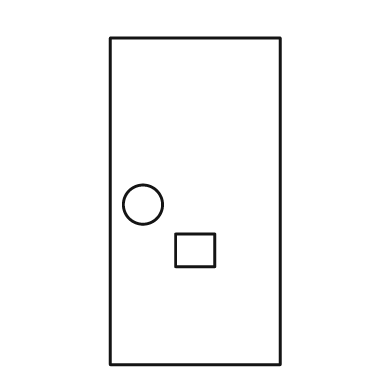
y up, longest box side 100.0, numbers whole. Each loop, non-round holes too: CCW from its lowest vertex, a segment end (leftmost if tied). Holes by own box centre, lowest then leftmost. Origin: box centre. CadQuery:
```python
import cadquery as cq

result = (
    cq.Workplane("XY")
    .moveTo(-26.0, -50.0)
    .lineTo(26.0, -50.0)
    .lineTo(26.0, 50.0)
    .lineTo(-26.0, 50.0)
    .close()
    .moveTo(-6.0, -20.0)
    .lineTo(6.0, -20.0)
    .lineTo(6.0, -10.0)
    .lineTo(-6.0, -10.0)
    .close()
    .moveTo(-16.0, -1.0)
    .circle(6.0)
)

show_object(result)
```